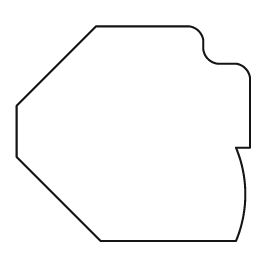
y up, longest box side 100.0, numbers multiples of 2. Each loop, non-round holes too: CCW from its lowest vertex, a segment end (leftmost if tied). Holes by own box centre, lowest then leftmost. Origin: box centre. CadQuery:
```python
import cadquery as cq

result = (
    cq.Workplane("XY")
    .moveTo(-14.0, -46.0)
    .lineTo(44.0, -46.0)
    .threePointArc((48.0, -26.0), (44.0, -6.0))
    .lineTo(50.0, -6.0)
    .lineTo(50.0, 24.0)
    .threePointArc((48.0, 28.0), (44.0, 30.0))
    .lineTo(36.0, 30.0)
    .threePointArc((32.0, 32.0), (30.0, 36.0))
    .lineTo(30.0, 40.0)
    .threePointArc((28.0, 44.0), (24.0, 46.0))
    .lineTo(-16.0, 46.0)
    .lineTo(-50.0, 12.0)
    .lineTo(-50.0, -10.0)
    .close()
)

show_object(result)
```